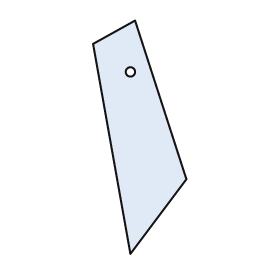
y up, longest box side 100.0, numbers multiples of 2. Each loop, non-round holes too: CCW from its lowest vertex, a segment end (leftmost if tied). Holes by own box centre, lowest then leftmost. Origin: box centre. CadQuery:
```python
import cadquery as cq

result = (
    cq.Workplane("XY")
    .moveTo(-4.0, -50.0)
    .lineTo(20.0, -18.0)
    .lineTo(-2.0, 50.0)
    .lineTo(-20.0, 40.0)
    .close()
    .moveTo(-4.0, 28.0)
    .circle(2.0)
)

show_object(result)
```